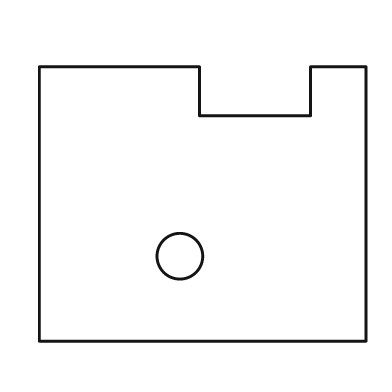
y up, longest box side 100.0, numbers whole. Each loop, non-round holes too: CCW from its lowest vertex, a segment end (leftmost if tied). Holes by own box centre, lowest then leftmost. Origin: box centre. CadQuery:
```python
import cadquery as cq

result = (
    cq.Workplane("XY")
    .moveTo(-50.0, -42.0)
    .lineTo(50.0, -42.0)
    .lineTo(50.0, 42.0)
    .lineTo(33.0, 42.0)
    .lineTo(33.0, 27.0)
    .lineTo(-1.0, 27.0)
    .lineTo(-1.0, 42.0)
    .lineTo(-50.0, 42.0)
    .close()
    .moveTo(-7.0, -16.0)
    .circle(7.0)
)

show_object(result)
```